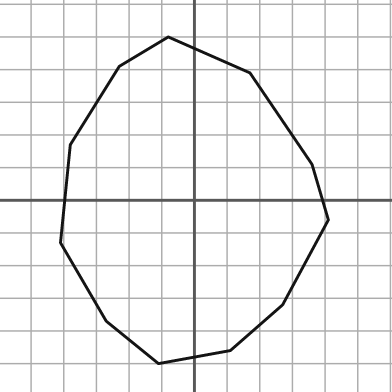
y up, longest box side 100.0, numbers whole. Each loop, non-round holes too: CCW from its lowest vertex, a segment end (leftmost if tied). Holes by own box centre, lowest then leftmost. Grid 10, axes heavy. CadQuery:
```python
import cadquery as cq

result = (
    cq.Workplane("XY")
    .moveTo(-11.0, -50.0)
    .lineTo(11.0, -46.0)
    .lineTo(27.0, -32.0)
    .lineTo(41.0, -6.0)
    .lineTo(36.0, 11.0)
    .lineTo(17.0, 39.0)
    .lineTo(-8.0, 50.0)
    .lineTo(-23.0, 41.0)
    .lineTo(-38.0, 17.0)
    .lineTo(-41.0, -13.0)
    .lineTo(-27.0, -37.0)
    .close()
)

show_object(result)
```